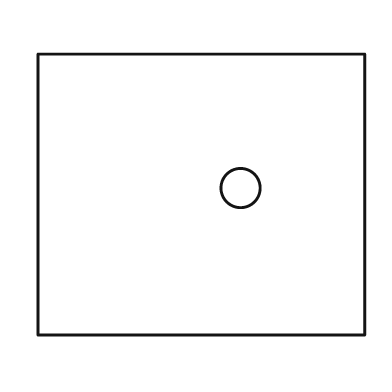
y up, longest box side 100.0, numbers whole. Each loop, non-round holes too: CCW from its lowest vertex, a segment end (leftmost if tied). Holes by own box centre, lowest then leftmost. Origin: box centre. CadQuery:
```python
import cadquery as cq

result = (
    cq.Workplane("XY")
    .moveTo(-50.0, -43.0)
    .lineTo(50.0, -43.0)
    .lineTo(50.0, 43.0)
    .lineTo(-50.0, 43.0)
    .close()
    .moveTo(12.0, 2.0)
    .circle(6.0)
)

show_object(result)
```